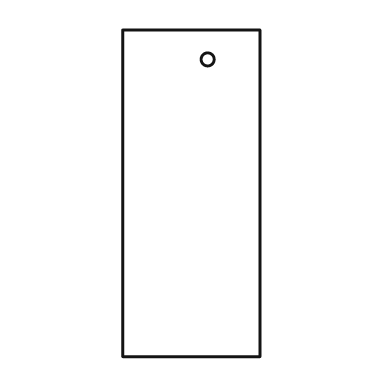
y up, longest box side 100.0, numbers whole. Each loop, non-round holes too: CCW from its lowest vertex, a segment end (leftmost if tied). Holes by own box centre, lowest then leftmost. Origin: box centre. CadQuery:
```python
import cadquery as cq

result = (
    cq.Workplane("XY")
    .moveTo(-21.0, -50.0)
    .lineTo(21.0, -50.0)
    .lineTo(21.0, 50.0)
    .lineTo(-21.0, 50.0)
    .close()
    .moveTo(5.0, 41.0)
    .circle(2.0)
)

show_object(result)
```